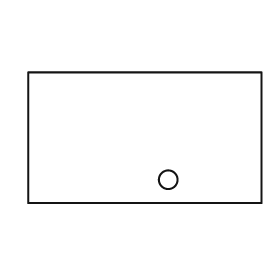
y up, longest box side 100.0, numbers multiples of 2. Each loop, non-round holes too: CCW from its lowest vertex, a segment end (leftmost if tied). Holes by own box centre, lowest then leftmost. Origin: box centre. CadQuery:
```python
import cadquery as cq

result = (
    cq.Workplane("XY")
    .moveTo(-50.0, -28.0)
    .lineTo(50.0, -28.0)
    .lineTo(50.0, 28.0)
    .lineTo(-50.0, 28.0)
    .close()
    .moveTo(10.0, -18.0)
    .circle(4.0)
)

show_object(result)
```